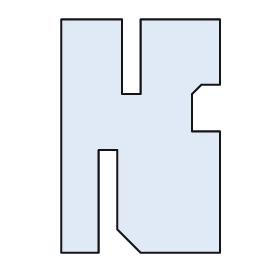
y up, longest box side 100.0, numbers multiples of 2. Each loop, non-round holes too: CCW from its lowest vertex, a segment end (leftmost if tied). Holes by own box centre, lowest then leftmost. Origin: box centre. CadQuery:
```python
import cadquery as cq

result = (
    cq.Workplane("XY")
    .moveTo(-34.0, -50.0)
    .lineTo(-18.0, -50.0)
    .lineTo(-18.0, -6.0)
    .lineTo(-10.0, -6.0)
    .lineTo(-10.0, -40.0)
    .lineTo(0.0, -50.0)
    .lineTo(34.0, -50.0)
    .lineTo(34.0, 2.0)
    .lineTo(22.0, 2.0)
    .lineTo(22.0, 18.0)
    .lineTo(26.0, 22.0)
    .lineTo(34.0, 22.0)
    .lineTo(34.0, 50.0)
    .lineTo(0.0, 50.0)
    .lineTo(0.0, 18.0)
    .lineTo(-8.0, 18.0)
    .lineTo(-8.0, 50.0)
    .lineTo(-34.0, 50.0)
    .close()
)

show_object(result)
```